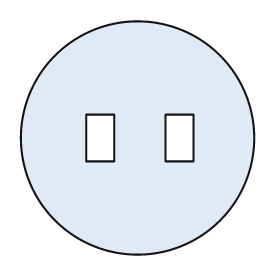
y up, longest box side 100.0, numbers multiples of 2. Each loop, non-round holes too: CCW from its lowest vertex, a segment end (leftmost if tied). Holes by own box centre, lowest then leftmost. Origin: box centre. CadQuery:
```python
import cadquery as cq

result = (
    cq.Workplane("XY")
    .moveTo(0.0, 0.0)
    .circle(50.0)
    .moveTo(-22.0, -10.0)
    .lineTo(-10.0, -10.0)
    .lineTo(-10.0, 10.0)
    .lineTo(-22.0, 10.0)
    .close()
    .moveTo(12.0, -10.0)
    .lineTo(24.0, -10.0)
    .lineTo(24.0, 10.0)
    .lineTo(12.0, 10.0)
    .close()
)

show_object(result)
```